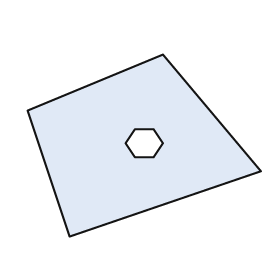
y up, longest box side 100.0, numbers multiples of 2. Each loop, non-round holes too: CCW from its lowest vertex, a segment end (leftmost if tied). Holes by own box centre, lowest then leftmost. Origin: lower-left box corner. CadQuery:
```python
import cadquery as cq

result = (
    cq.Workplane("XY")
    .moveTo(18.0, 0.0)
    .lineTo(100.0, 28.0)
    .lineTo(58.0, 78.0)
    .lineTo(0.0, 54.0)
    .close()
    .moveTo(46.0, 34.0)
    .lineTo(54.0, 34.0)
    .lineTo(58.0, 40.0)
    .lineTo(54.0, 46.0)
    .lineTo(46.0, 46.0)
    .lineTo(42.0, 40.0)
    .close()
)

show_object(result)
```